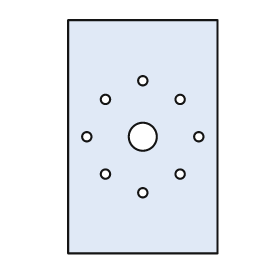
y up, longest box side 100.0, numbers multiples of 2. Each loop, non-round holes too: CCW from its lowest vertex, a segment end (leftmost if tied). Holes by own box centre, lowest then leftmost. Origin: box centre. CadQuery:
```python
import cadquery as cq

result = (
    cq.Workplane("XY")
    .moveTo(-32.0, -50.0)
    .lineTo(32.0, -50.0)
    .lineTo(32.0, 50.0)
    .lineTo(-32.0, 50.0)
    .close()
    .moveTo(0.0, -24.0)
    .circle(2.0)
    .moveTo(-16.0, -16.0)
    .circle(2.0)
    .moveTo(16.0, -16.0)
    .circle(2.0)
    .moveTo(-24.0, 0.0)
    .circle(2.0)
    .moveTo(0.0, 0.0)
    .circle(6.0)
    .moveTo(24.0, 0.0)
    .circle(2.0)
    .moveTo(-16.0, 16.0)
    .circle(2.0)
    .moveTo(16.0, 16.0)
    .circle(2.0)
    .moveTo(0.0, 24.0)
    .circle(2.0)
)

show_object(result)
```